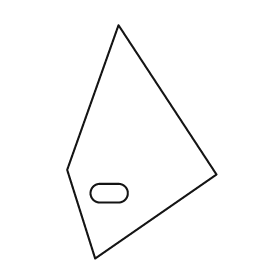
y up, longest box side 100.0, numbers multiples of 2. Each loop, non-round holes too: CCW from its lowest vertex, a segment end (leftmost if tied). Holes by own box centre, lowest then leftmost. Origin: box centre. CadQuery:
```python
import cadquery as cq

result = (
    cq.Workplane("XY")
    .moveTo(-20.0, -50.0)
    .lineTo(32.0, -14.0)
    .lineTo(-10.0, 50.0)
    .lineTo(-32.0, -12.0)
    .close()
    .moveTo(-18.0, -26.0)
    .lineTo(-10.0, -26.0)
    .threePointArc((-6.0, -22.0), (-10.0, -18.0))
    .lineTo(-18.0, -18.0)
    .threePointArc((-22.0, -22.0), (-18.0, -26.0))
    .close()
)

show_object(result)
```